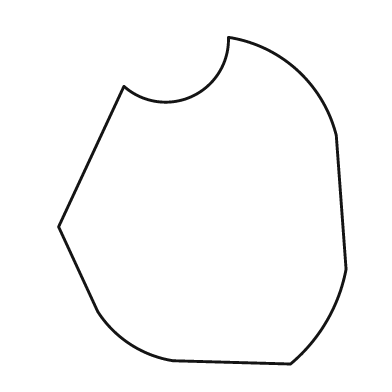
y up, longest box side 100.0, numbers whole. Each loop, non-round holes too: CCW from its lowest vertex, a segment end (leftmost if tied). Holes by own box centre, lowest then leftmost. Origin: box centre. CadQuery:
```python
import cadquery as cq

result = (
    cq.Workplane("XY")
    .moveTo(27.0, -50.0)
    .threePointArc((38.0, -37.0), (44.0, -21.0))
    .lineTo(41.0, 20.0)
    .threePointArc((29.0, 40.0), (8.0, 50.0))
    .threePointArc((-3.0, 32.0), (-24.0, 35.0))
    .lineTo(-44.0, -8.0)
    .lineTo(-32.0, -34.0)
    .threePointArc((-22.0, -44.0), (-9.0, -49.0))
    .close()
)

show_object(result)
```